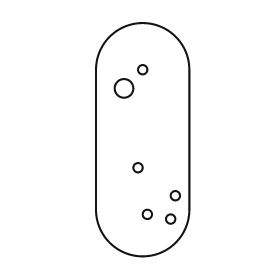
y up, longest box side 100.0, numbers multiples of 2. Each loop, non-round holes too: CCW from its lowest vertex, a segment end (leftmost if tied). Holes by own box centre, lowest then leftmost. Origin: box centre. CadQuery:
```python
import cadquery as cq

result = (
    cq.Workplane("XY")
    .moveTo(-20.0, -30.0)
    .threePointArc((0.0, -50.0), (20.0, -30.0))
    .lineTo(20.0, 30.0)
    .threePointArc((0.0, 50.0), (-20.0, 30.0))
    .close()
    .moveTo(12.0, -34.0)
    .circle(2.0)
    .moveTo(2.0, -32.0)
    .circle(2.0)
    .moveTo(14.0, -24.0)
    .circle(2.0)
    .moveTo(-2.0, -12.0)
    .circle(2.0)
    .moveTo(-8.0, 22.0)
    .circle(4.0)
    .moveTo(0.0, 30.0)
    .circle(2.0)
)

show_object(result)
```